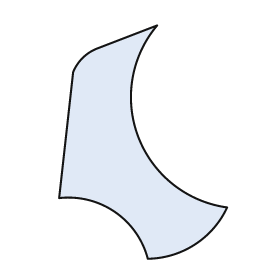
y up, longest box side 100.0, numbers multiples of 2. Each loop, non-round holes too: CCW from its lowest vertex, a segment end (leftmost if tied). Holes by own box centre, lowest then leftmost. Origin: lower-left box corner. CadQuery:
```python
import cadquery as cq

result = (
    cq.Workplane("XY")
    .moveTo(38.0, 0.0)
    .threePointArc((58.0, 6.0), (72.0, 22.0))
    .threePointArc((34.0, 52.0), (42.0, 100.0))
    .lineTo(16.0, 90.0)
    .threePointArc((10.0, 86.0), (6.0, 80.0))
    .lineTo(0.0, 26.0)
    .threePointArc((24.0, 20.0), (38.0, 0.0))
    .close()
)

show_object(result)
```